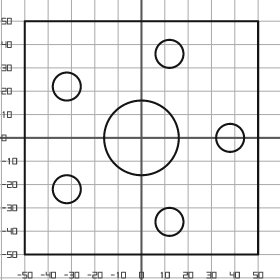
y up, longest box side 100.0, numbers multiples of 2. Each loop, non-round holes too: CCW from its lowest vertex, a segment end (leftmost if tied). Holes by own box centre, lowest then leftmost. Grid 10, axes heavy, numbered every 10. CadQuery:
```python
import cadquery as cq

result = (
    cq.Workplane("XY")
    .moveTo(-50.0, -50.0)
    .lineTo(50.0, -50.0)
    .lineTo(50.0, 50.0)
    .lineTo(-50.0, 50.0)
    .close()
    .moveTo(12.0, -36.0)
    .circle(6.0)
    .moveTo(-32.0, -22.0)
    .circle(6.0)
    .moveTo(0.0, 0.0)
    .circle(16.0)
    .moveTo(38.0, 0.0)
    .circle(6.0)
    .moveTo(-32.0, 22.0)
    .circle(6.0)
    .moveTo(12.0, 36.0)
    .circle(6.0)
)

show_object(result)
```